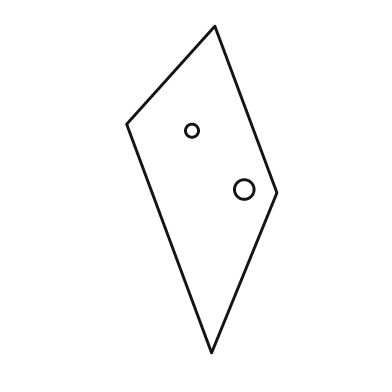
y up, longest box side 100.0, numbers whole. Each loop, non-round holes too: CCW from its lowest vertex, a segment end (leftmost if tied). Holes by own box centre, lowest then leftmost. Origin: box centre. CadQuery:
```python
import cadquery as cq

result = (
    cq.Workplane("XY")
    .moveTo(3.0, -50.0)
    .lineTo(23.0, -1.0)
    .lineTo(4.0, 50.0)
    .lineTo(-23.0, 20.0)
    .close()
    .moveTo(13.0, 0.0)
    .circle(3.0)
    .moveTo(-3.0, 18.0)
    .circle(2.0)
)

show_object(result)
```